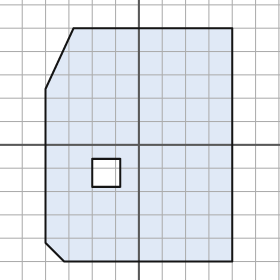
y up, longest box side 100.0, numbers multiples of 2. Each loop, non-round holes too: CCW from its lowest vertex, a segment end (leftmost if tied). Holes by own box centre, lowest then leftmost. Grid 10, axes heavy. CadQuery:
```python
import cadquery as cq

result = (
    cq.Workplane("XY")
    .moveTo(-32.0, -50.0)
    .lineTo(40.0, -50.0)
    .lineTo(40.0, 50.0)
    .lineTo(-28.0, 50.0)
    .lineTo(-40.0, 24.0)
    .lineTo(-40.0, -42.0)
    .close()
    .moveTo(-20.0, -18.0)
    .lineTo(-8.0, -18.0)
    .lineTo(-8.0, -6.0)
    .lineTo(-20.0, -6.0)
    .close()
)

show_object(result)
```